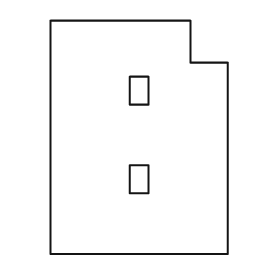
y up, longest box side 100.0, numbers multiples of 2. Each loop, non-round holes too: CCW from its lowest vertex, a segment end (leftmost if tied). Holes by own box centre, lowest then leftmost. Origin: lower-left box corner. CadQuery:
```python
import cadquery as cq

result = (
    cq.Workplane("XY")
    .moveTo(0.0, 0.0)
    .lineTo(76.0, 0.0)
    .lineTo(76.0, 82.0)
    .lineTo(60.0, 82.0)
    .lineTo(60.0, 100.0)
    .lineTo(0.0, 100.0)
    .close()
    .moveTo(34.0, 26.0)
    .lineTo(42.0, 26.0)
    .lineTo(42.0, 38.0)
    .lineTo(34.0, 38.0)
    .close()
    .moveTo(34.0, 64.0)
    .lineTo(42.0, 64.0)
    .lineTo(42.0, 76.0)
    .lineTo(34.0, 76.0)
    .close()
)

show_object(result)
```